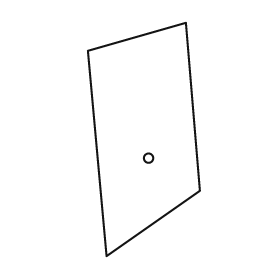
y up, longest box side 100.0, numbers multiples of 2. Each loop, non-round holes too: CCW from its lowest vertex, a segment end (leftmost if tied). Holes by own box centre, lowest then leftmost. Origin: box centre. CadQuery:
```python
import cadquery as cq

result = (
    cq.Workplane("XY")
    .moveTo(-16.0, -50.0)
    .lineTo(24.0, -22.0)
    .lineTo(18.0, 50.0)
    .lineTo(-24.0, 38.0)
    .close()
    .moveTo(2.0, -8.0)
    .circle(2.0)
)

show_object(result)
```